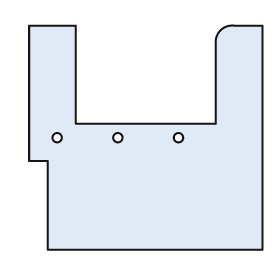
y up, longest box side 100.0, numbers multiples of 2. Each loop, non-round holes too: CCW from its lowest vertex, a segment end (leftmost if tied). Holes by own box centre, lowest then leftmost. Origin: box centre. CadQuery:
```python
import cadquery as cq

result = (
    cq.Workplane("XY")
    .moveTo(-42.0, -48.0)
    .lineTo(50.0, -48.0)
    .lineTo(50.0, 48.0)
    .lineTo(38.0, 48.0)
    .threePointArc((32.0, 46.0), (30.0, 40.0))
    .lineTo(30.0, 6.0)
    .lineTo(-30.0, 6.0)
    .lineTo(-30.0, 48.0)
    .lineTo(-50.0, 48.0)
    .lineTo(-50.0, -10.0)
    .lineTo(-42.0, -10.0)
    .close()
    .moveTo(-38.0, 0.0)
    .circle(2.0)
    .moveTo(-12.0, 0.0)
    .circle(2.0)
    .moveTo(14.0, 0.0)
    .circle(2.0)
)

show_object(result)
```